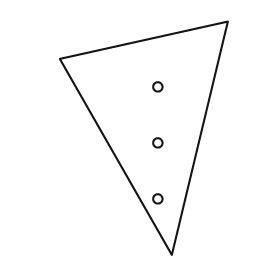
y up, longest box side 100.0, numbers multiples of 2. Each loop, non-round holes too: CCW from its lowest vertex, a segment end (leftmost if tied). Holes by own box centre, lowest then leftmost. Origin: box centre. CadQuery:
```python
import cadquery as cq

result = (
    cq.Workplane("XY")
    .moveTo(12.0, -50.0)
    .lineTo(36.0, 50.0)
    .lineTo(-36.0, 34.0)
    .close()
    .moveTo(6.0, -26.0)
    .circle(2.0)
    .moveTo(6.0, -2.0)
    .circle(2.0)
    .moveTo(6.0, 22.0)
    .circle(2.0)
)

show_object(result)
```